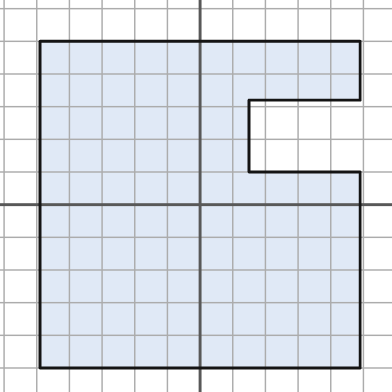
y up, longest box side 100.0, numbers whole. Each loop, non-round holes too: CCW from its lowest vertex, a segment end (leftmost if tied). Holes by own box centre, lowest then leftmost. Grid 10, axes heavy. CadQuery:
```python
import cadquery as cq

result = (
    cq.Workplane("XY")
    .moveTo(-49.0, -50.0)
    .lineTo(49.0, -50.0)
    .lineTo(49.0, 10.0)
    .lineTo(15.0, 10.0)
    .lineTo(15.0, 32.0)
    .lineTo(49.0, 32.0)
    .lineTo(49.0, 50.0)
    .lineTo(-49.0, 50.0)
    .close()
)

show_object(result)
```